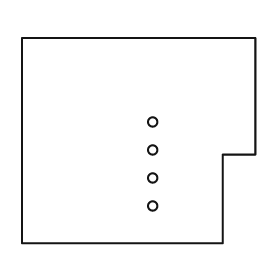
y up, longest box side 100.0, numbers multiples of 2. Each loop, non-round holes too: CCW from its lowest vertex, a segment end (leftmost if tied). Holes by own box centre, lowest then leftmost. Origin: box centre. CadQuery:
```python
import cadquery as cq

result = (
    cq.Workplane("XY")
    .moveTo(-50.0, -44.0)
    .lineTo(36.0, -44.0)
    .lineTo(36.0, -6.0)
    .lineTo(50.0, -6.0)
    .lineTo(50.0, 44.0)
    .lineTo(-50.0, 44.0)
    .close()
    .moveTo(6.0, -28.0)
    .circle(2.0)
    .moveTo(6.0, -16.0)
    .circle(2.0)
    .moveTo(6.0, -4.0)
    .circle(2.0)
    .moveTo(6.0, 8.0)
    .circle(2.0)
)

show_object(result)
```